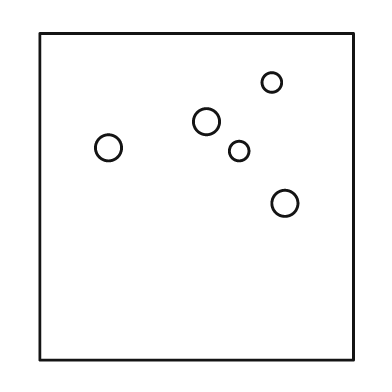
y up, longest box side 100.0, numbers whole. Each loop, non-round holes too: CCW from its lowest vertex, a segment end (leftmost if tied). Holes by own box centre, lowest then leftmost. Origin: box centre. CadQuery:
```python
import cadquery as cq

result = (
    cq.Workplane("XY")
    .moveTo(-48.0, -50.0)
    .lineTo(48.0, -50.0)
    .lineTo(48.0, 50.0)
    .lineTo(-48.0, 50.0)
    .close()
    .moveTo(27.0, -2.0)
    .circle(4.0)
    .moveTo(13.0, 14.0)
    .circle(3.0)
    .moveTo(-27.0, 15.0)
    .circle(4.0)
    .moveTo(3.0, 23.0)
    .circle(4.0)
    .moveTo(23.0, 35.0)
    .circle(3.0)
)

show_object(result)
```